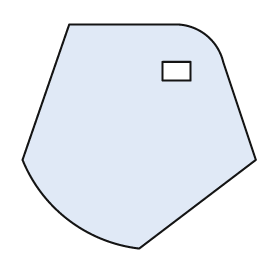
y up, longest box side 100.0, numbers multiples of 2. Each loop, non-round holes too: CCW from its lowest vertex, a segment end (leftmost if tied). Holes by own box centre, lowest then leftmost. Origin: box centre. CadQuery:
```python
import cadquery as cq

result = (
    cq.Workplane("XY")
    .moveTo(0.0, -48.0)
    .lineTo(50.0, -10.0)
    .lineTo(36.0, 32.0)
    .threePointArc((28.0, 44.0), (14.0, 48.0))
    .lineTo(-30.0, 48.0)
    .lineTo(-50.0, -10.0)
    .threePointArc((-30.0, -36.0), (0.0, -48.0))
    .close()
    .moveTo(10.0, 24.0)
    .lineTo(22.0, 24.0)
    .lineTo(22.0, 32.0)
    .lineTo(10.0, 32.0)
    .close()
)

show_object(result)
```